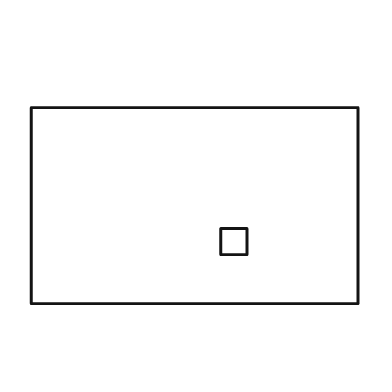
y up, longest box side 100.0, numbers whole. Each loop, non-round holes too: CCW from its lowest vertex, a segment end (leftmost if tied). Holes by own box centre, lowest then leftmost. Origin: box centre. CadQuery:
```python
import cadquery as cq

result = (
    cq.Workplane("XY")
    .moveTo(-50.0, -30.0)
    .lineTo(50.0, -30.0)
    .lineTo(50.0, 30.0)
    .lineTo(-50.0, 30.0)
    .close()
    .moveTo(8.0, -15.0)
    .lineTo(16.0, -15.0)
    .lineTo(16.0, -7.0)
    .lineTo(8.0, -7.0)
    .close()
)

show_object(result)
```